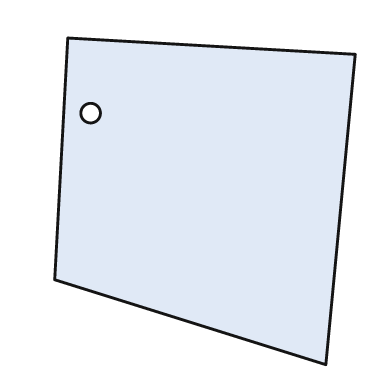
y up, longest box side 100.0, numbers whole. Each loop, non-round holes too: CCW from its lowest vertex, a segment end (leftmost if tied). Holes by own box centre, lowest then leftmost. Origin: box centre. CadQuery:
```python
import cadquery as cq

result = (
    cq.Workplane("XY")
    .moveTo(37.0, -50.0)
    .lineTo(46.0, 45.0)
    .lineTo(-42.0, 50.0)
    .lineTo(-46.0, -24.0)
    .close()
    .moveTo(-35.0, 27.0)
    .circle(3.0)
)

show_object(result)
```